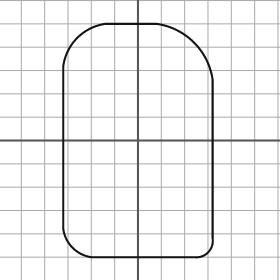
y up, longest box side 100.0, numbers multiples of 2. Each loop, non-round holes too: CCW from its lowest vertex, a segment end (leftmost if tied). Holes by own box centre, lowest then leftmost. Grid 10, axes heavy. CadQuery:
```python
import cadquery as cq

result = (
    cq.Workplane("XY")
    .moveTo(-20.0, -50.0)
    .lineTo(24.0, -50.0)
    .threePointArc((30.0, -48.0), (32.0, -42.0))
    .lineTo(32.0, 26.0)
    .threePointArc((24.0, 42.0), (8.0, 50.0))
    .lineTo(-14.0, 50.0)
    .threePointArc((-26.0, 44.0), (-32.0, 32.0))
    .lineTo(-32.0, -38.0)
    .threePointArc((-28.0, -46.0), (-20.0, -50.0))
    .close()
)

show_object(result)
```